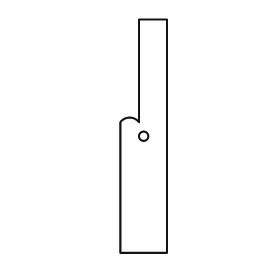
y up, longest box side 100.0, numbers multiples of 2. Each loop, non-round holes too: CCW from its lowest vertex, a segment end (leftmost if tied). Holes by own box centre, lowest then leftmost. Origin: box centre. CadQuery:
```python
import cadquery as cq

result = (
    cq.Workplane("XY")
    .moveTo(-10.0, -50.0)
    .lineTo(10.0, -50.0)
    .lineTo(10.0, 50.0)
    .lineTo(-2.0, 50.0)
    .lineTo(-2.0, 6.0)
    .threePointArc((-6.0, 8.0), (-10.0, 6.0))
    .close()
    .moveTo(0.0, 0.0)
    .circle(2.0)
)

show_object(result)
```